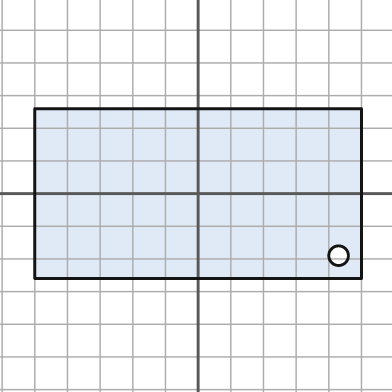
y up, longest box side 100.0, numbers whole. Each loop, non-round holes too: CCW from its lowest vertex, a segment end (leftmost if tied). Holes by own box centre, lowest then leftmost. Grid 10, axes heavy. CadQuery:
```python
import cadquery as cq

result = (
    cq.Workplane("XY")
    .moveTo(-50.0, -26.0)
    .lineTo(50.0, -26.0)
    .lineTo(50.0, 26.0)
    .lineTo(-50.0, 26.0)
    .close()
    .moveTo(43.0, -19.0)
    .circle(3.0)
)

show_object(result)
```